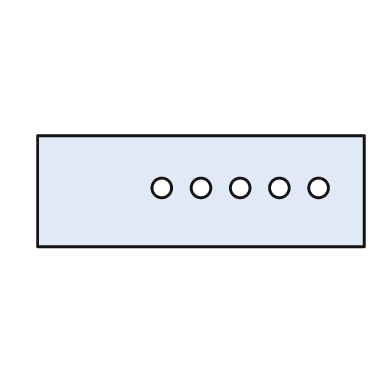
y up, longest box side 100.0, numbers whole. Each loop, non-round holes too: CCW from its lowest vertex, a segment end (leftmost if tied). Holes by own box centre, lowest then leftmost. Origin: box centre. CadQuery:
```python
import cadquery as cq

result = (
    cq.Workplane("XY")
    .moveTo(-50.0, -17.0)
    .lineTo(50.0, -17.0)
    .lineTo(50.0, 17.0)
    .lineTo(-50.0, 17.0)
    .close()
    .moveTo(-12.0, 1.0)
    .circle(3.0)
    .moveTo(0.0, 1.0)
    .circle(3.0)
    .moveTo(12.0, 1.0)
    .circle(3.0)
    .moveTo(24.0, 1.0)
    .circle(3.0)
    .moveTo(36.0, 1.0)
    .circle(3.0)
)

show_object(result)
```